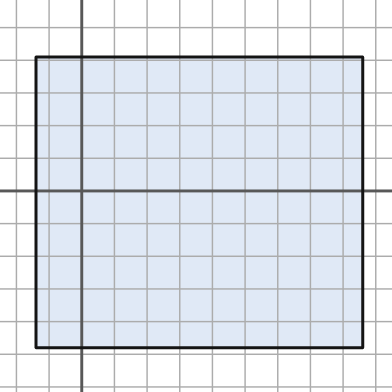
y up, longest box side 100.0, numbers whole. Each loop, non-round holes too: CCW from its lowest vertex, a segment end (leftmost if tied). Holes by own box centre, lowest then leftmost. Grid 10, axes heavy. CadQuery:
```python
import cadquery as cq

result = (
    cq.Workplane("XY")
    .moveTo(-14.0, -48.0)
    .lineTo(86.0, -48.0)
    .lineTo(86.0, 41.0)
    .lineTo(-14.0, 41.0)
    .close()
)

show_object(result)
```